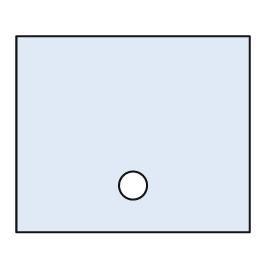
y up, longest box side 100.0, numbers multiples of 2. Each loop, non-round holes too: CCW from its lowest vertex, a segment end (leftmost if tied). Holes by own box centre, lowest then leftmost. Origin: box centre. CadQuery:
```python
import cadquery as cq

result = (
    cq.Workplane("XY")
    .moveTo(-50.0, -42.0)
    .lineTo(50.0, -42.0)
    .lineTo(50.0, 42.0)
    .lineTo(-50.0, 42.0)
    .close()
    .moveTo(0.0, -22.0)
    .circle(6.0)
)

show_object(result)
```